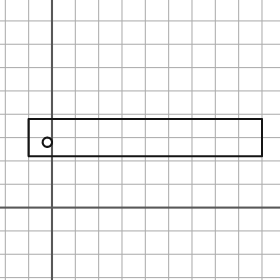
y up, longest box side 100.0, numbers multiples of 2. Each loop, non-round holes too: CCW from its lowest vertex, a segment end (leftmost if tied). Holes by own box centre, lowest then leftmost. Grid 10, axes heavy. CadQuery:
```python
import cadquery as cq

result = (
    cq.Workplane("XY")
    .moveTo(-10.0, 22.0)
    .lineTo(90.0, 22.0)
    .lineTo(90.0, 38.0)
    .lineTo(-10.0, 38.0)
    .close()
    .moveTo(-2.0, 28.0)
    .circle(2.0)
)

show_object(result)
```